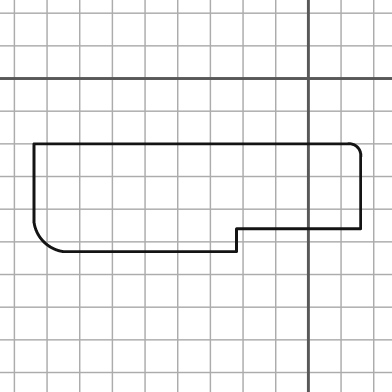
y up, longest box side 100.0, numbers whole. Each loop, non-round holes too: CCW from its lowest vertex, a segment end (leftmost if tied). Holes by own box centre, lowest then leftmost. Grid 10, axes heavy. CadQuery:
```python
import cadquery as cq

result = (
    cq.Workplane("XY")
    .moveTo(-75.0, -53.0)
    .lineTo(-22.0, -53.0)
    .lineTo(-22.0, -46.0)
    .lineTo(16.0, -46.0)
    .lineTo(16.0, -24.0)
    .threePointArc((15.0, -21.0), (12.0, -20.0))
    .lineTo(-84.0, -20.0)
    .lineTo(-84.0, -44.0)
    .threePointArc((-81.0, -50.0), (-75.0, -53.0))
    .close()
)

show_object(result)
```